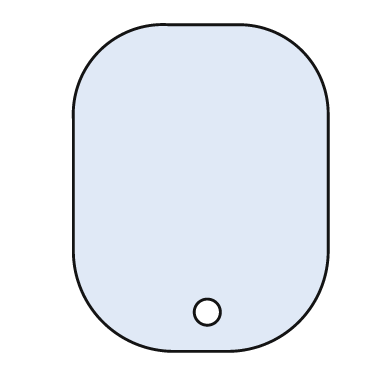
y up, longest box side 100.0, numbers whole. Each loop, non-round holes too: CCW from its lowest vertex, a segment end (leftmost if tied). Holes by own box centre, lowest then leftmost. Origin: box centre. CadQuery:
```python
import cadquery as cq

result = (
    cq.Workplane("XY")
    .moveTo(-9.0, -50.0)
    .lineTo(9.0, -50.0)
    .threePointArc((30.0, -41.0), (39.0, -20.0))
    .lineTo(39.0, 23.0)
    .threePointArc((31.0, 42.0), (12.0, 50.0))
    .lineTo(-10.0, 50.0)
    .threePointArc((-31.0, 42.0), (-39.0, 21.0))
    .lineTo(-39.0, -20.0)
    .threePointArc((-30.0, -41.0), (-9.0, -50.0))
    .close()
    .moveTo(2.0, -38.0)
    .circle(4.0)
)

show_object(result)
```